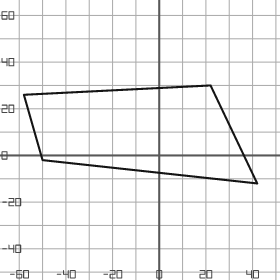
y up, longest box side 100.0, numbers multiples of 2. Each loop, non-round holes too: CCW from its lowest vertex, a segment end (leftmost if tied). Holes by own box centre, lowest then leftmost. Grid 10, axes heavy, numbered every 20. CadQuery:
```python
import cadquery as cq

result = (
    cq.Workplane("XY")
    .moveTo(42.0, -12.0)
    .lineTo(22.0, 30.0)
    .lineTo(-58.0, 26.0)
    .lineTo(-50.0, -2.0)
    .close()
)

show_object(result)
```